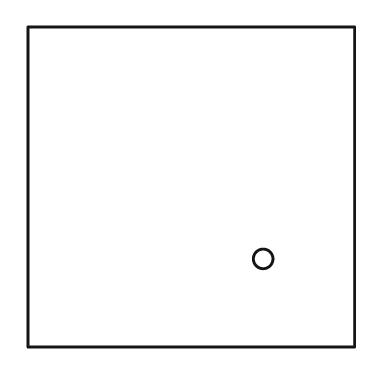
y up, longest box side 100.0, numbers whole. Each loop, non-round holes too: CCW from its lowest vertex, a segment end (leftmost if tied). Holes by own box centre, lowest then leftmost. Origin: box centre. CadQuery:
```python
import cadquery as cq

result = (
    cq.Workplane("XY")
    .moveTo(-50.0, -49.0)
    .lineTo(50.0, -49.0)
    .lineTo(50.0, 49.0)
    .lineTo(-50.0, 49.0)
    .close()
    .moveTo(22.0, -22.0)
    .circle(3.0)
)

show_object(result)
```